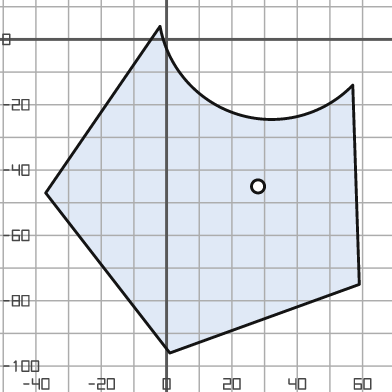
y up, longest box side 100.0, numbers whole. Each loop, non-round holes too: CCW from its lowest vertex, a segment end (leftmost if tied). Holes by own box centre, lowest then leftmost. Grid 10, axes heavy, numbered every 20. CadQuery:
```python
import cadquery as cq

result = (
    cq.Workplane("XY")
    .moveTo(1.0, -96.0)
    .lineTo(59.0, -75.0)
    .lineTo(57.0, -14.0)
    .threePointArc((22.0, -23.0), (-2.0, 4.0))
    .lineTo(-37.0, -47.0)
    .close()
    .moveTo(28.0, -45.0)
    .circle(2.0)
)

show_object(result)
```